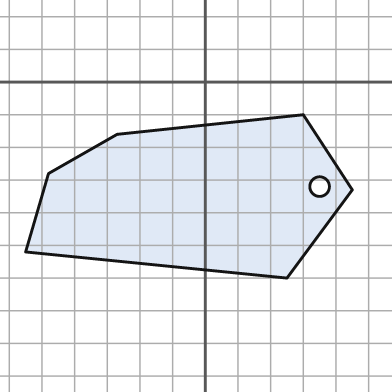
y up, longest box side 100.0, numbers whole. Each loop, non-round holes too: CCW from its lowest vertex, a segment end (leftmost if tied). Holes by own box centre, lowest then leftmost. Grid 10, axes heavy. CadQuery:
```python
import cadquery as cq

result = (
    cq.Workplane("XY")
    .moveTo(25.0, -60.0)
    .lineTo(45.0, -33.0)
    .lineTo(30.0, -10.0)
    .lineTo(-27.0, -16.0)
    .lineTo(-48.0, -28.0)
    .lineTo(-55.0, -52.0)
    .close()
    .moveTo(35.0, -32.0)
    .circle(3.0)
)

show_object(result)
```